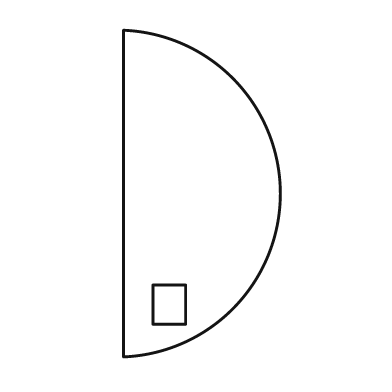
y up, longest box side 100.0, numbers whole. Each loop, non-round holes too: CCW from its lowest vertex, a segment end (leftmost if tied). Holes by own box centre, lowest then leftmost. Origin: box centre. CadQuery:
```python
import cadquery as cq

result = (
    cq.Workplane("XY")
    .moveTo(-24.0, -50.0)
    .threePointArc((24.0, 0.0), (-24.0, 50.0))
    .close()
    .moveTo(-15.0, -40.0)
    .lineTo(-5.0, -40.0)
    .lineTo(-5.0, -28.0)
    .lineTo(-15.0, -28.0)
    .close()
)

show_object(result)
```